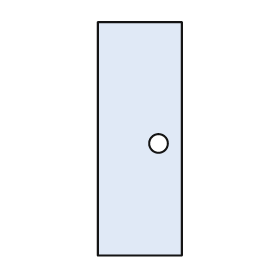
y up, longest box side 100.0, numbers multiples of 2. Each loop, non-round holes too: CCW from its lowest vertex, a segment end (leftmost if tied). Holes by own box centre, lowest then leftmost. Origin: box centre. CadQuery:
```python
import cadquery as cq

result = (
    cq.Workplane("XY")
    .moveTo(-18.0, -50.0)
    .lineTo(18.0, -50.0)
    .lineTo(18.0, 50.0)
    .lineTo(-18.0, 50.0)
    .close()
    .moveTo(8.0, -2.0)
    .circle(4.0)
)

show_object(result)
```